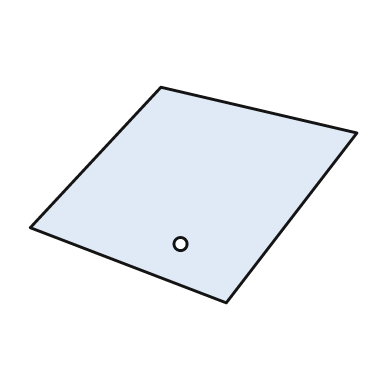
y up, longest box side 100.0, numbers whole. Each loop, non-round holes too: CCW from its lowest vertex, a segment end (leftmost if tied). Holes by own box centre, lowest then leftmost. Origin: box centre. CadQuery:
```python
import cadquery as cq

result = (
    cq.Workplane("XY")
    .moveTo(10.0, -33.0)
    .lineTo(50.0, 19.0)
    .lineTo(-10.0, 33.0)
    .lineTo(-50.0, -10.0)
    .close()
    .moveTo(-4.0, -15.0)
    .circle(2.0)
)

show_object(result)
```